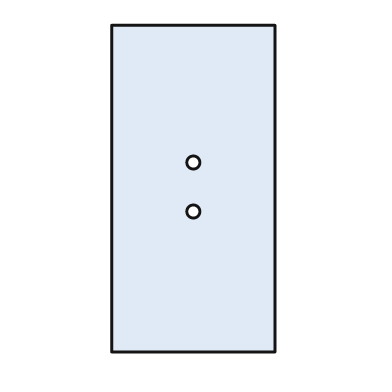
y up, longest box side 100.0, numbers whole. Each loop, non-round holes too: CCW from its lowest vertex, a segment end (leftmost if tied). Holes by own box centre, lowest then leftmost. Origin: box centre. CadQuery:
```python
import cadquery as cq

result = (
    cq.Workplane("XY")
    .moveTo(-25.0, -50.0)
    .lineTo(25.0, -50.0)
    .lineTo(25.0, 50.0)
    .lineTo(-25.0, 50.0)
    .close()
    .moveTo(0.0, -7.0)
    .circle(2.0)
    .moveTo(0.0, 8.0)
    .circle(2.0)
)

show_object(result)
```